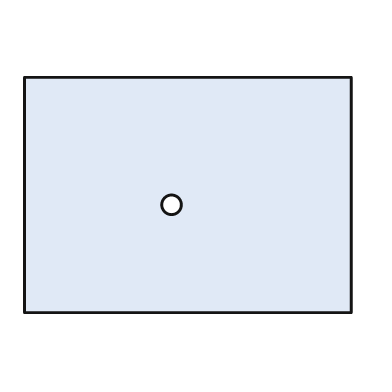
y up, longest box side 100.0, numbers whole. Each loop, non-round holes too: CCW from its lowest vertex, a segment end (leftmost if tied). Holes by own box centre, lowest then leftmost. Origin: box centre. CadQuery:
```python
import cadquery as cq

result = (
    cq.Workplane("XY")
    .moveTo(-50.0, -36.0)
    .lineTo(50.0, -36.0)
    .lineTo(50.0, 36.0)
    .lineTo(-50.0, 36.0)
    .close()
    .moveTo(-5.0, -3.0)
    .circle(3.0)
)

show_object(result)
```